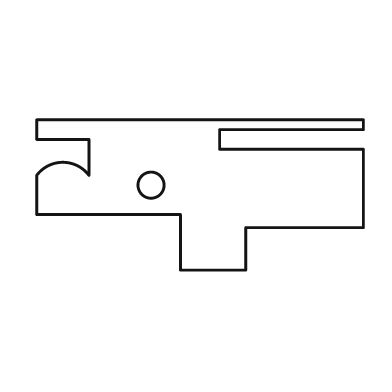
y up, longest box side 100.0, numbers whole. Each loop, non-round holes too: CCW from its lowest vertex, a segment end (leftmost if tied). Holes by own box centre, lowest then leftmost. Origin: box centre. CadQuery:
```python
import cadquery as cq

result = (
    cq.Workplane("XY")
    .moveTo(-6.0, -23.0)
    .lineTo(14.0, -23.0)
    .lineTo(14.0, -10.0)
    .lineTo(50.0, -10.0)
    .lineTo(50.0, 14.0)
    .lineTo(6.0, 14.0)
    .lineTo(6.0, 20.0)
    .lineTo(50.0, 20.0)
    .lineTo(50.0, 23.0)
    .lineTo(-50.0, 23.0)
    .lineTo(-50.0, 17.0)
    .lineTo(-34.0, 17.0)
    .lineTo(-34.0, 6.0)
    .threePointArc((-42.0, 10.0), (-50.0, 6.0))
    .lineTo(-50.0, -6.0)
    .lineTo(-6.0, -6.0)
    .close()
    .moveTo(-15.0, 3.0)
    .circle(4.0)
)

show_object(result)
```